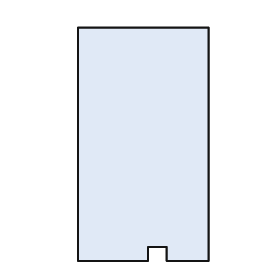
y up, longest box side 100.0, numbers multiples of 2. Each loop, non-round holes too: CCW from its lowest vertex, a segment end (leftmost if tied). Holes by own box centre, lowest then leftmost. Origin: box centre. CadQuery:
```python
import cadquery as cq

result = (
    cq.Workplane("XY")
    .moveTo(-28.0, -50.0)
    .lineTo(2.0, -50.0)
    .lineTo(2.0, -44.0)
    .lineTo(10.0, -44.0)
    .lineTo(10.0, -50.0)
    .lineTo(28.0, -50.0)
    .lineTo(28.0, 50.0)
    .lineTo(-28.0, 50.0)
    .close()
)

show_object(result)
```